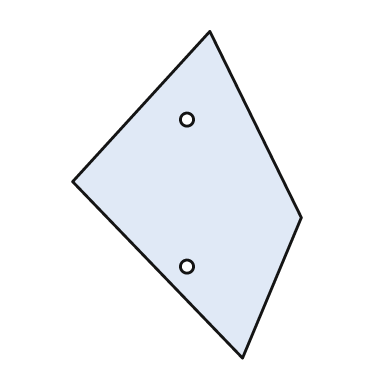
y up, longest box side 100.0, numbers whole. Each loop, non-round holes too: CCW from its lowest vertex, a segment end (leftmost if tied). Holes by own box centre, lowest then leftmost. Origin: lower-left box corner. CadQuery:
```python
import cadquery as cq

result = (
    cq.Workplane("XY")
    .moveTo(52.0, 0.0)
    .lineTo(70.0, 43.0)
    .lineTo(42.0, 100.0)
    .lineTo(0.0, 54.0)
    .close()
    .moveTo(35.0, 28.0)
    .circle(2.0)
    .moveTo(35.0, 73.0)
    .circle(2.0)
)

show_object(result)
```